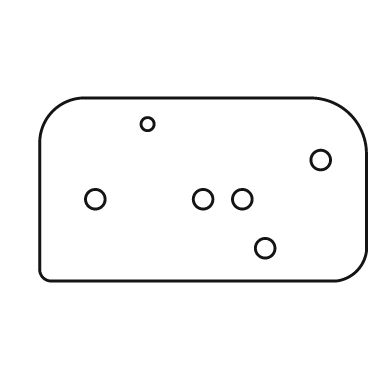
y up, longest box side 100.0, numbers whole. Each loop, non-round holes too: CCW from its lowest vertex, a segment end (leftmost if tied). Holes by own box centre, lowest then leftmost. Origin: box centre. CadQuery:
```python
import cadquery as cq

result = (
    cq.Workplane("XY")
    .moveTo(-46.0, -28.0)
    .lineTo(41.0, -28.0)
    .threePointArc((47.0, -25.0), (50.0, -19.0))
    .lineTo(50.0, 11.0)
    .threePointArc((45.0, 23.0), (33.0, 28.0))
    .lineTo(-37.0, 28.0)
    .threePointArc((-46.0, 24.0), (-50.0, 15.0))
    .lineTo(-50.0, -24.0)
    .threePointArc((-49.0, -27.0), (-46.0, -28.0))
    .close()
    .moveTo(19.0, -18.0)
    .circle(3.0)
    .moveTo(-33.0, -3.0)
    .circle(3.0)
    .moveTo(0.0, -3.0)
    .circle(3.0)
    .moveTo(12.0, -3.0)
    .circle(3.0)
    .moveTo(36.0, 9.0)
    .circle(3.0)
    .moveTo(-17.0, 20.0)
    .circle(2.0)
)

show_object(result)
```